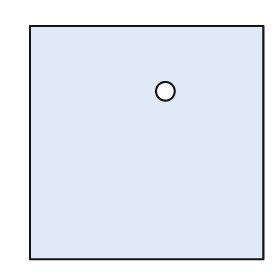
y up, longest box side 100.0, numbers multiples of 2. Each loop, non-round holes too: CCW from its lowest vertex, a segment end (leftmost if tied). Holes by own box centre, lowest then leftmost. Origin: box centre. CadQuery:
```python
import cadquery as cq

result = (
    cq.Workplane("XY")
    .moveTo(-50.0, -50.0)
    .lineTo(50.0, -50.0)
    .lineTo(50.0, 50.0)
    .lineTo(-50.0, 50.0)
    .close()
    .moveTo(8.0, 22.0)
    .circle(4.0)
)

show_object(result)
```